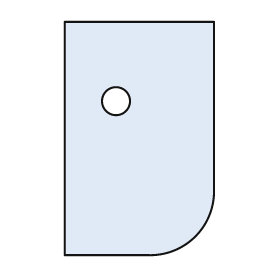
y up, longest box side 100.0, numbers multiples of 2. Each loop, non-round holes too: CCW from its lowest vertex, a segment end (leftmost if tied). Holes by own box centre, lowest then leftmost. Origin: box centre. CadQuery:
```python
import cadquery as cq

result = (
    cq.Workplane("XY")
    .moveTo(-32.0, -50.0)
    .lineTo(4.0, -50.0)
    .threePointArc((24.0, -42.0), (32.0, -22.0))
    .lineTo(32.0, 50.0)
    .lineTo(-32.0, 50.0)
    .close()
    .moveTo(-10.0, 16.0)
    .circle(6.0)
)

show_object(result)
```